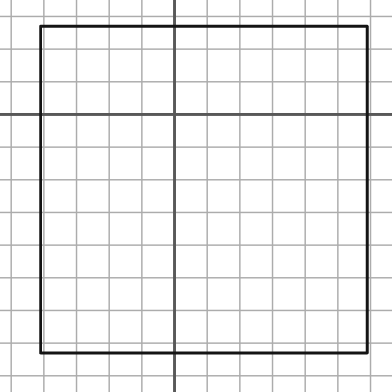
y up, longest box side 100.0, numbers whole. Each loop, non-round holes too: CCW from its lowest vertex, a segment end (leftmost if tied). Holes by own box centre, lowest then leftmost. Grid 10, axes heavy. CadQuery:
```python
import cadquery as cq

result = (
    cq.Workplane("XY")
    .moveTo(-41.0, -73.0)
    .lineTo(59.0, -73.0)
    .lineTo(59.0, 27.0)
    .lineTo(-41.0, 27.0)
    .close()
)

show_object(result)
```